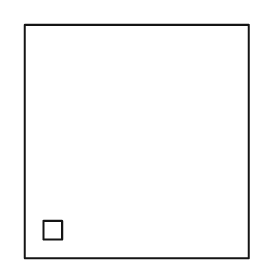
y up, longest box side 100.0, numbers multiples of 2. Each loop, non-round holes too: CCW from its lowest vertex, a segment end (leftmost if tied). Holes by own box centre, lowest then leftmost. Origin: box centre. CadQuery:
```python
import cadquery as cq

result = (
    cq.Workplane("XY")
    .moveTo(-48.0, -50.0)
    .lineTo(48.0, -50.0)
    .lineTo(48.0, 50.0)
    .lineTo(-48.0, 50.0)
    .close()
    .moveTo(-40.0, -42.0)
    .lineTo(-32.0, -42.0)
    .lineTo(-32.0, -34.0)
    .lineTo(-40.0, -34.0)
    .close()
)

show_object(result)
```